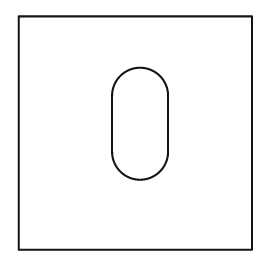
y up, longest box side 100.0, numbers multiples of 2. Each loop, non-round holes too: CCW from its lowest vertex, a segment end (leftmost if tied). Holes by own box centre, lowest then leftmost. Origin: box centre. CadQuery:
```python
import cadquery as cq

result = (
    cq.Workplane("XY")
    .moveTo(-50.0, -50.0)
    .lineTo(50.0, -50.0)
    .lineTo(50.0, 50.0)
    .lineTo(-50.0, 50.0)
    .close()
    .moveTo(-10.0, -8.0)
    .threePointArc((2.0, -20.0), (14.0, -8.0))
    .lineTo(14.0, 16.0)
    .threePointArc((2.0, 28.0), (-10.0, 16.0))
    .close()
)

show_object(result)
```